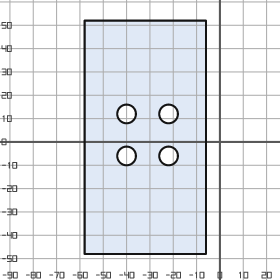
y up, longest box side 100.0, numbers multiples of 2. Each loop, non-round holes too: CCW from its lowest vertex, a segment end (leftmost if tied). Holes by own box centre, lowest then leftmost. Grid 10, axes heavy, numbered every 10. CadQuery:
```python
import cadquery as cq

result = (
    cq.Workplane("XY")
    .moveTo(-58.0, -48.0)
    .lineTo(-6.0, -48.0)
    .lineTo(-6.0, 52.0)
    .lineTo(-58.0, 52.0)
    .close()
    .moveTo(-40.0, -6.0)
    .circle(4.0)
    .moveTo(-22.0, -6.0)
    .circle(4.0)
    .moveTo(-40.0, 12.0)
    .circle(4.0)
    .moveTo(-22.0, 12.0)
    .circle(4.0)
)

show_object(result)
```